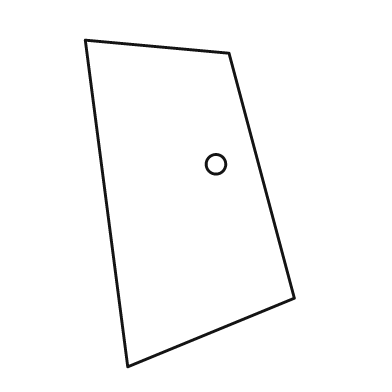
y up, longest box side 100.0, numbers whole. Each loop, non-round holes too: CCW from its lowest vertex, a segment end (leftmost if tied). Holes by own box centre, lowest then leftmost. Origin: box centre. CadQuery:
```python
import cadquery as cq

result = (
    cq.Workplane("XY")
    .moveTo(-19.0, -50.0)
    .lineTo(32.0, -29.0)
    .lineTo(12.0, 46.0)
    .lineTo(-32.0, 50.0)
    .close()
    .moveTo(8.0, 12.0)
    .circle(3.0)
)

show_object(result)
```